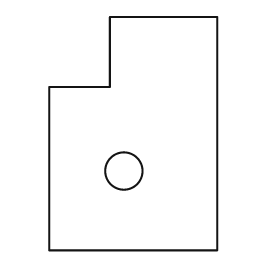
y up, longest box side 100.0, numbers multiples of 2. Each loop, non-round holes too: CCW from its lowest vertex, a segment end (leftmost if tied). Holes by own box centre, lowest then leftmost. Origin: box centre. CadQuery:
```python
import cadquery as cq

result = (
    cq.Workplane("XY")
    .moveTo(-36.0, -50.0)
    .lineTo(36.0, -50.0)
    .lineTo(36.0, 50.0)
    .lineTo(-10.0, 50.0)
    .lineTo(-10.0, 20.0)
    .lineTo(-36.0, 20.0)
    .close()
    .moveTo(-4.0, -16.0)
    .circle(8.0)
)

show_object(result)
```